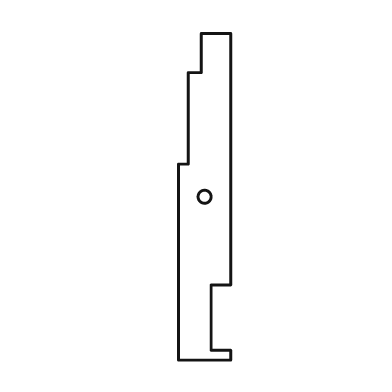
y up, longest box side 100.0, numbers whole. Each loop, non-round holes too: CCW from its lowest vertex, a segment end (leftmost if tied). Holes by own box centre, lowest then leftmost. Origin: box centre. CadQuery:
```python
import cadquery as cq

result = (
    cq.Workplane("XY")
    .moveTo(-8.0, -50.0)
    .lineTo(8.0, -50.0)
    .lineTo(8.0, -47.0)
    .lineTo(2.0, -47.0)
    .lineTo(2.0, -27.0)
    .lineTo(8.0, -27.0)
    .lineTo(8.0, 50.0)
    .lineTo(-1.0, 50.0)
    .lineTo(-1.0, 38.0)
    .lineTo(-5.0, 38.0)
    .lineTo(-5.0, 10.0)
    .lineTo(-8.0, 10.0)
    .close()
    .moveTo(0.0, 0.0)
    .circle(2.0)
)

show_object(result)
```